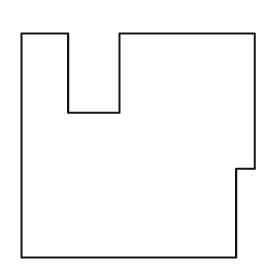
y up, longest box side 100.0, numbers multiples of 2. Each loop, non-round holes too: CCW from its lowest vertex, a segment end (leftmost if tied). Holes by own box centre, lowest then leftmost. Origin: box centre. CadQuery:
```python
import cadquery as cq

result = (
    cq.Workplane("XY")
    .moveTo(-50.0, -48.0)
    .lineTo(42.0, -48.0)
    .lineTo(42.0, -10.0)
    .lineTo(50.0, -10.0)
    .lineTo(50.0, 48.0)
    .lineTo(-8.0, 48.0)
    .lineTo(-8.0, 14.0)
    .lineTo(-30.0, 14.0)
    .lineTo(-30.0, 48.0)
    .lineTo(-50.0, 48.0)
    .close()
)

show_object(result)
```